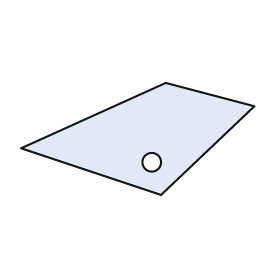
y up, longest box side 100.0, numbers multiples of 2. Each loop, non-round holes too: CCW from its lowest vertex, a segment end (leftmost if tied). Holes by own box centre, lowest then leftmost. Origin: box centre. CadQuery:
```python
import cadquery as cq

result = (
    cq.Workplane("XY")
    .moveTo(10.0, -24.0)
    .lineTo(50.0, 14.0)
    .lineTo(12.0, 24.0)
    .lineTo(-50.0, -4.0)
    .close()
    .moveTo(6.0, -10.0)
    .circle(4.0)
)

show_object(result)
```